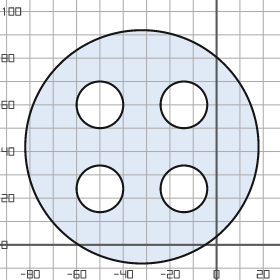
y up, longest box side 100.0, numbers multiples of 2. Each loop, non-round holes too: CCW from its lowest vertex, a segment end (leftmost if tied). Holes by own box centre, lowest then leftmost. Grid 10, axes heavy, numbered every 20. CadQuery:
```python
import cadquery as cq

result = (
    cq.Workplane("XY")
    .moveTo(-32.0, 42.0)
    .circle(50.0)
    .moveTo(-50.0, 24.0)
    .circle(10.0)
    .moveTo(-14.0, 24.0)
    .circle(10.0)
    .moveTo(-50.0, 60.0)
    .circle(10.0)
    .moveTo(-14.0, 60.0)
    .circle(10.0)
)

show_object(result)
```